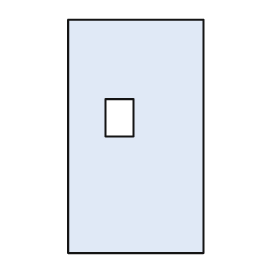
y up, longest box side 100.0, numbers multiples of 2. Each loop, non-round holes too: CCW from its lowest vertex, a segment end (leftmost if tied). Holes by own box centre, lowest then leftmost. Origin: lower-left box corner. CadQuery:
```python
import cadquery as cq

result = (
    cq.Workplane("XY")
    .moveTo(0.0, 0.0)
    .lineTo(58.0, 0.0)
    .lineTo(58.0, 100.0)
    .lineTo(0.0, 100.0)
    .close()
    .moveTo(16.0, 50.0)
    .lineTo(28.0, 50.0)
    .lineTo(28.0, 66.0)
    .lineTo(16.0, 66.0)
    .close()
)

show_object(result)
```